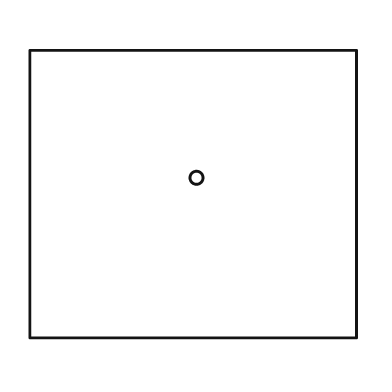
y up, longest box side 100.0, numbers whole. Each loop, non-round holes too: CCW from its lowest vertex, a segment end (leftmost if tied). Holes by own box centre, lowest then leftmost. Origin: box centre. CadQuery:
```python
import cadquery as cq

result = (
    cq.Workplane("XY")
    .moveTo(-50.0, -44.0)
    .lineTo(50.0, -44.0)
    .lineTo(50.0, 44.0)
    .lineTo(-50.0, 44.0)
    .close()
    .moveTo(1.0, 5.0)
    .circle(2.0)
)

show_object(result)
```